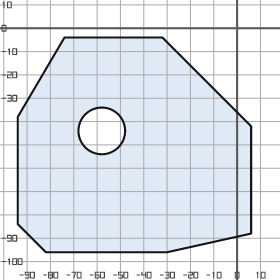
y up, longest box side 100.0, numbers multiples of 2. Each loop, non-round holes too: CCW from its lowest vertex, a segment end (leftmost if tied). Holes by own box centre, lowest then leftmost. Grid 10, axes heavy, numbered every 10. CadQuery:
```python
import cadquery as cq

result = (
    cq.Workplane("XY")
    .moveTo(-82.0, -96.0)
    .lineTo(-30.0, -96.0)
    .lineTo(6.0, -88.0)
    .lineTo(6.0, -42.0)
    .lineTo(-32.0, -4.0)
    .lineTo(-74.0, -4.0)
    .lineTo(-94.0, -38.0)
    .lineTo(-94.0, -84.0)
    .close()
    .moveTo(-58.0, -44.0)
    .circle(10.0)
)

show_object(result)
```